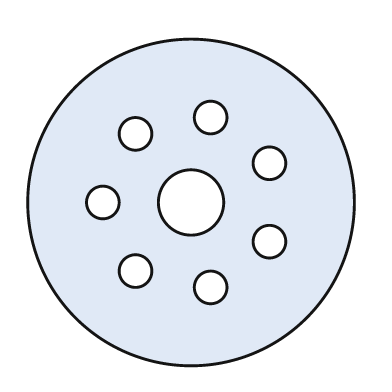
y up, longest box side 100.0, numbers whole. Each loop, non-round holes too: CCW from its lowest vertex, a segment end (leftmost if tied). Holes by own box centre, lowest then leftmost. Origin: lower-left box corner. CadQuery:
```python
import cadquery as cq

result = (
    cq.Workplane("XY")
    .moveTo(50.0, 50.0)
    .circle(50.0)
    .moveTo(56.0, 24.0)
    .circle(5.0)
    .moveTo(33.0, 29.0)
    .circle(5.0)
    .moveTo(74.0, 38.0)
    .circle(5.0)
    .moveTo(23.0, 50.0)
    .circle(5.0)
    .moveTo(50.0, 50.0)
    .circle(10.0)
    .moveTo(74.0, 62.0)
    .circle(5.0)
    .moveTo(33.0, 71.0)
    .circle(5.0)
    .moveTo(56.0, 76.0)
    .circle(5.0)
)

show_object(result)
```